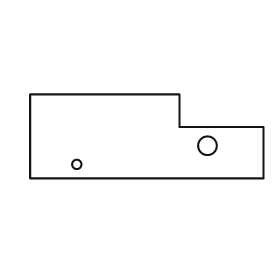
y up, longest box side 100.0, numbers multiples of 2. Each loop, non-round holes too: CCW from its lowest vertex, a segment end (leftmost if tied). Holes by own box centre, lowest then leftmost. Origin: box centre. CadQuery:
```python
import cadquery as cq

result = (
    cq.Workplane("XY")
    .moveTo(-50.0, -18.0)
    .lineTo(50.0, -18.0)
    .lineTo(50.0, 4.0)
    .lineTo(14.0, 4.0)
    .lineTo(14.0, 18.0)
    .lineTo(-50.0, 18.0)
    .close()
    .moveTo(-30.0, -12.0)
    .circle(2.0)
    .moveTo(26.0, -4.0)
    .circle(4.0)
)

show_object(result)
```